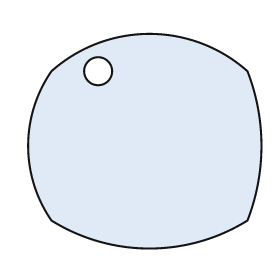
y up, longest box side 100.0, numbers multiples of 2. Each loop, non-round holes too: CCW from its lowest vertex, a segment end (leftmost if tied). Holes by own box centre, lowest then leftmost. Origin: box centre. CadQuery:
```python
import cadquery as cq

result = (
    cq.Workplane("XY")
    .moveTo(-40.0, -34.0)
    .threePointArc((2.0, -46.0), (44.0, -34.0))
    .threePointArc((50.0, -2.0), (44.0, 30.0))
    .threePointArc((2.0, 46.0), (-40.0, 30.0))
    .threePointArc((-50.0, -2.0), (-40.0, -34.0))
    .close()
    .moveTo(-20.0, 30.0)
    .circle(6.0)
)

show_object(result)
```